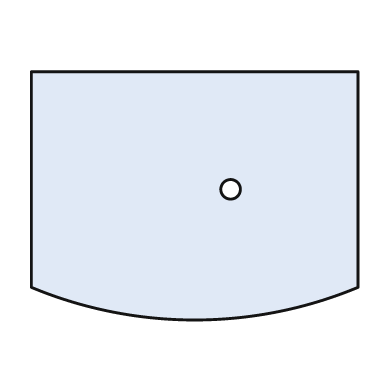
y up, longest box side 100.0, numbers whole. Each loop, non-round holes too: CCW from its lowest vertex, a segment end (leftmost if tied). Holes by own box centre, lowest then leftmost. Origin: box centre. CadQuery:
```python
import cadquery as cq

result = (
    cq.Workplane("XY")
    .moveTo(-50.0, -28.0)
    .threePointArc((0.0, -38.0), (50.0, -28.0))
    .lineTo(50.0, 38.0)
    .lineTo(-50.0, 38.0)
    .close()
    .moveTo(11.0, 2.0)
    .circle(3.0)
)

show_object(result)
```